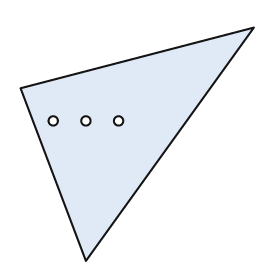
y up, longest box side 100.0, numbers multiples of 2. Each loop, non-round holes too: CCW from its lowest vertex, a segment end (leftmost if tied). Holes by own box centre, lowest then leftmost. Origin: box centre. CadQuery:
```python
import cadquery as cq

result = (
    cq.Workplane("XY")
    .moveTo(-22.0, -50.0)
    .lineTo(50.0, 50.0)
    .lineTo(-50.0, 24.0)
    .close()
    .moveTo(-36.0, 10.0)
    .circle(2.0)
    .moveTo(-22.0, 10.0)
    .circle(2.0)
    .moveTo(-8.0, 10.0)
    .circle(2.0)
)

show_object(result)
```